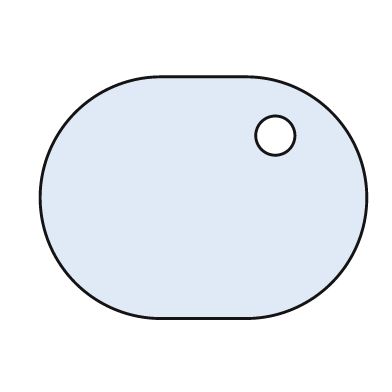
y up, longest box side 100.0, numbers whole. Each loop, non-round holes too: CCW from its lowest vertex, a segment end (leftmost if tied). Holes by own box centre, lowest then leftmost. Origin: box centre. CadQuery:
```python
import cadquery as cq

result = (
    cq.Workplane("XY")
    .moveTo(-13.0, -37.0)
    .lineTo(13.0, -37.0)
    .threePointArc((50.0, 0.0), (13.0, 37.0))
    .lineTo(-13.0, 37.0)
    .threePointArc((-50.0, 0.0), (-13.0, -37.0))
    .close()
    .moveTo(22.0, 19.0)
    .circle(6.0)
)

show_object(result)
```